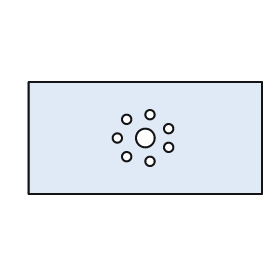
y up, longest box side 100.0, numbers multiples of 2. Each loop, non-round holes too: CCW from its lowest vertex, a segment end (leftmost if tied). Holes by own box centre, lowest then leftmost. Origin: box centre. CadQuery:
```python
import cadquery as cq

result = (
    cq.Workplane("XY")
    .moveTo(-50.0, -24.0)
    .lineTo(50.0, -24.0)
    .lineTo(50.0, 24.0)
    .lineTo(-50.0, 24.0)
    .close()
    .moveTo(2.0, -10.0)
    .circle(2.0)
    .moveTo(-8.0, -8.0)
    .circle(2.0)
    .moveTo(10.0, -4.0)
    .circle(2.0)
    .moveTo(-12.0, 0.0)
    .circle(2.0)
    .moveTo(0.0, 0.0)
    .circle(4.0)
    .moveTo(10.0, 4.0)
    .circle(2.0)
    .moveTo(-8.0, 8.0)
    .circle(2.0)
    .moveTo(2.0, 10.0)
    .circle(2.0)
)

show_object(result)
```